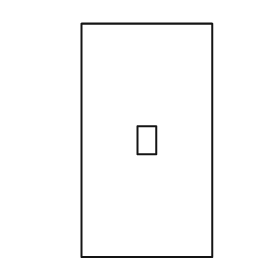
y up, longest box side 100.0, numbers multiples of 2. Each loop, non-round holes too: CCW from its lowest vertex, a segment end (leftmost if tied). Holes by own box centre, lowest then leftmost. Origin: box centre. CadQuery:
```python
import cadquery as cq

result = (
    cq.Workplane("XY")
    .moveTo(-28.0, -50.0)
    .lineTo(28.0, -50.0)
    .lineTo(28.0, 50.0)
    .lineTo(-28.0, 50.0)
    .close()
    .moveTo(-4.0, -6.0)
    .lineTo(4.0, -6.0)
    .lineTo(4.0, 6.0)
    .lineTo(-4.0, 6.0)
    .close()
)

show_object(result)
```